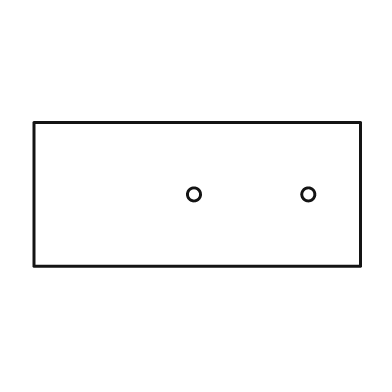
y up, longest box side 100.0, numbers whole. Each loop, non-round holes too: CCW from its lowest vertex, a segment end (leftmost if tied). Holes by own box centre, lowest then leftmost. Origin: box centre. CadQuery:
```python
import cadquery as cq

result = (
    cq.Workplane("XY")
    .moveTo(-50.0, -22.0)
    .lineTo(50.0, -22.0)
    .lineTo(50.0, 22.0)
    .lineTo(-50.0, 22.0)
    .close()
    .moveTo(-1.0, 0.0)
    .circle(2.0)
    .moveTo(34.0, 0.0)
    .circle(2.0)
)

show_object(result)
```